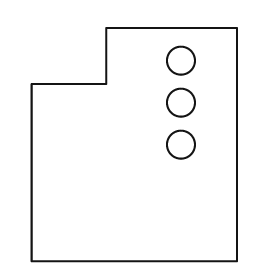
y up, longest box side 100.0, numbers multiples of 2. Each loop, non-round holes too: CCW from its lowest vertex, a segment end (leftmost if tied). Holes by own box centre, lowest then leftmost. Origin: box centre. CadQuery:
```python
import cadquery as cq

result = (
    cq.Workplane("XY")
    .moveTo(-44.0, -50.0)
    .lineTo(44.0, -50.0)
    .lineTo(44.0, 50.0)
    .lineTo(-12.0, 50.0)
    .lineTo(-12.0, 26.0)
    .lineTo(-44.0, 26.0)
    .close()
    .moveTo(20.0, 0.0)
    .circle(6.0)
    .moveTo(20.0, 18.0)
    .circle(6.0)
    .moveTo(20.0, 36.0)
    .circle(6.0)
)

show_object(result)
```